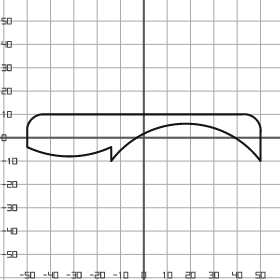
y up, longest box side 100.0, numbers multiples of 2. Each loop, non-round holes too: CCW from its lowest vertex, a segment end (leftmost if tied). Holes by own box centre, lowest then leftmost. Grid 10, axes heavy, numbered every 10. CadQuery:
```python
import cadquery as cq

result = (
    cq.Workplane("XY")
    .moveTo(-14.0, -10.0)
    .threePointArc((18.0, 6.0), (50.0, -10.0))
    .lineTo(50.0, 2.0)
    .threePointArc((48.0, 8.0), (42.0, 10.0))
    .lineTo(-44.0, 10.0)
    .threePointArc((-48.0, 8.0), (-50.0, 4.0))
    .lineTo(-50.0, -4.0)
    .threePointArc((-32.0, -8.0), (-14.0, -4.0))
    .close()
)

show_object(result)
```